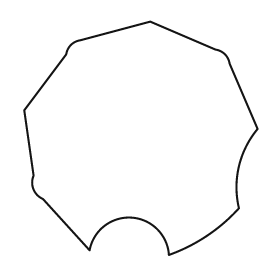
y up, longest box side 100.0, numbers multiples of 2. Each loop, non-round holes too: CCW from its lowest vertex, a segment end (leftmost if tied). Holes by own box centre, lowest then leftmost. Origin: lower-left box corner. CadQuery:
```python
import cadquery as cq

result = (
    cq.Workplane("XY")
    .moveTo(62.0, 0.0)
    .threePointArc((78.0, 8.0), (92.0, 20.0))
    .threePointArc((92.0, 38.0), (100.0, 54.0))
    .lineTo(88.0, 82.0)
    .threePointArc((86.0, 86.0), (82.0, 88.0))
    .lineTo(54.0, 100.0)
    .lineTo(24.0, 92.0)
    .threePointArc((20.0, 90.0), (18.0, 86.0))
    .lineTo(0.0, 62.0)
    .lineTo(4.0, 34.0)
    .threePointArc((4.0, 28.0), (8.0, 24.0))
    .lineTo(28.0, 2.0)
    .threePointArc((46.0, 16.0), (62.0, 0.0))
    .close()
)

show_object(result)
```